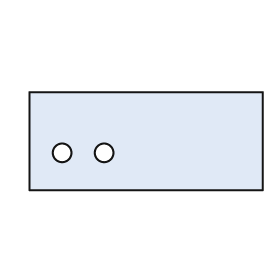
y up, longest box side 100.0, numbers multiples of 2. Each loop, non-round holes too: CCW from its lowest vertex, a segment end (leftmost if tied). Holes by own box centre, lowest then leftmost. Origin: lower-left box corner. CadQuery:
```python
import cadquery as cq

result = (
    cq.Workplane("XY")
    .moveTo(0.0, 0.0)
    .lineTo(100.0, 0.0)
    .lineTo(100.0, 42.0)
    .lineTo(0.0, 42.0)
    .close()
    .moveTo(14.0, 16.0)
    .circle(4.0)
    .moveTo(32.0, 16.0)
    .circle(4.0)
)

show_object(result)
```